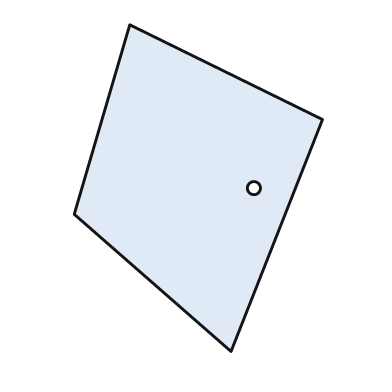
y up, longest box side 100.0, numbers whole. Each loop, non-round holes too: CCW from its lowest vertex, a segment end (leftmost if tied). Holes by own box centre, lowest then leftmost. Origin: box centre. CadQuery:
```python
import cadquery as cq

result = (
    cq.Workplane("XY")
    .moveTo(10.0, -50.0)
    .lineTo(38.0, 21.0)
    .lineTo(-21.0, 50.0)
    .lineTo(-38.0, -8.0)
    .close()
    .moveTo(17.0, 0.0)
    .circle(2.0)
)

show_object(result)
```